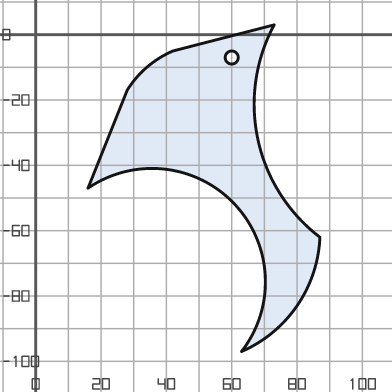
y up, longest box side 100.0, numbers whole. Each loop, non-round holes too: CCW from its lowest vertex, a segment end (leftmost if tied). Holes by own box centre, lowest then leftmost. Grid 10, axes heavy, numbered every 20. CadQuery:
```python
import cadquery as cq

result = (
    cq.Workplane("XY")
    .moveTo(63.0, -97.0)
    .threePointArc((80.0, -83.0), (87.0, -62.0))
    .threePointArc((68.0, -32.0), (73.0, 3.0))
    .lineTo(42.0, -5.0)
    .threePointArc((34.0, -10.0), (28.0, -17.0))
    .lineTo(16.0, -47.0)
    .threePointArc((61.0, -52.0), (63.0, -97.0))
    .close()
    .moveTo(60.0, -7.0)
    .circle(2.0)
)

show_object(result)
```